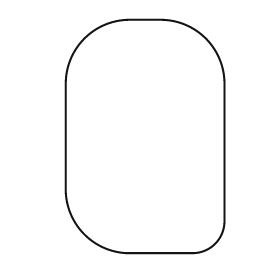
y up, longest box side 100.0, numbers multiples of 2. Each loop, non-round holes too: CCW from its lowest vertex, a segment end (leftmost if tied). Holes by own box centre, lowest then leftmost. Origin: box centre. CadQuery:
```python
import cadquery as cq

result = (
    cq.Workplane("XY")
    .moveTo(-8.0, -50.0)
    .lineTo(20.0, -50.0)
    .threePointArc((30.0, -46.0), (34.0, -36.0))
    .lineTo(34.0, 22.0)
    .threePointArc((26.0, 42.0), (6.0, 50.0))
    .lineTo(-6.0, 50.0)
    .threePointArc((-26.0, 42.0), (-34.0, 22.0))
    .lineTo(-34.0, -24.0)
    .threePointArc((-26.0, -42.0), (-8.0, -50.0))
    .close()
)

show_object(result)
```